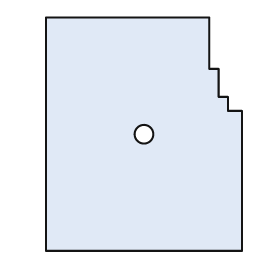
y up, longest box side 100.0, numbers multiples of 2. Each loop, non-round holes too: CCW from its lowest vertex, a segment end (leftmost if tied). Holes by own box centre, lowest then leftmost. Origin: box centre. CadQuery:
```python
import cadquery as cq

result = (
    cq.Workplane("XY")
    .moveTo(-42.0, -50.0)
    .lineTo(42.0, -50.0)
    .lineTo(42.0, 10.0)
    .lineTo(36.0, 10.0)
    .lineTo(36.0, 16.0)
    .lineTo(32.0, 16.0)
    .lineTo(32.0, 28.0)
    .lineTo(28.0, 28.0)
    .lineTo(28.0, 50.0)
    .lineTo(-42.0, 50.0)
    .close()
    .moveTo(0.0, 0.0)
    .circle(4.0)
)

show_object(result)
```